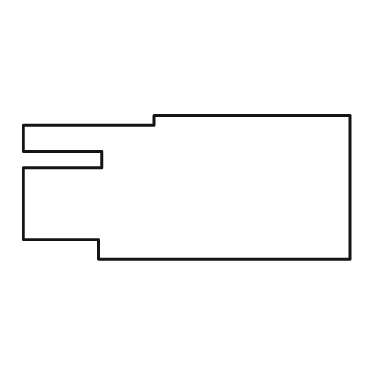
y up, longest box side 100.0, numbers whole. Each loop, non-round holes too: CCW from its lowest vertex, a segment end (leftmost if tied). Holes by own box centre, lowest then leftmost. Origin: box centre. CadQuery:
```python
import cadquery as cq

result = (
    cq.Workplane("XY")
    .moveTo(-27.0, -22.0)
    .lineTo(50.0, -22.0)
    .lineTo(50.0, 22.0)
    .lineTo(-10.0, 22.0)
    .lineTo(-10.0, 19.0)
    .lineTo(-50.0, 19.0)
    .lineTo(-50.0, 11.0)
    .lineTo(-26.0, 11.0)
    .lineTo(-26.0, 6.0)
    .lineTo(-50.0, 6.0)
    .lineTo(-50.0, -16.0)
    .lineTo(-27.0, -16.0)
    .close()
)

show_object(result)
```